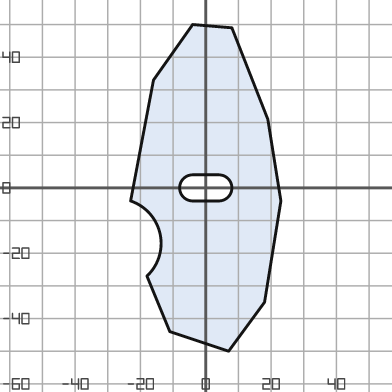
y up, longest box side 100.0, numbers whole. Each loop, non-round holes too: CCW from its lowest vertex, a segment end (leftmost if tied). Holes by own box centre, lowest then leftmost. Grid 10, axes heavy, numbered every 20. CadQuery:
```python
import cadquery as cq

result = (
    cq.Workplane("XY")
    .moveTo(7.0, -50.0)
    .lineTo(18.0, -35.0)
    .lineTo(23.0, -4.0)
    .lineTo(19.0, 21.0)
    .lineTo(8.0, 49.0)
    .lineTo(-4.0, 50.0)
    .lineTo(-16.0, 33.0)
    .lineTo(-23.0, -4.0)
    .threePointArc((-14.0, -14.0), (-18.0, -27.0))
    .lineTo(-11.0, -44.0)
    .close()
    .moveTo(-4.0, -4.0)
    .lineTo(4.0, -4.0)
    .threePointArc((8.0, 0.0), (4.0, 4.0))
    .lineTo(-4.0, 4.0)
    .threePointArc((-8.0, 0.0), (-4.0, -4.0))
    .close()
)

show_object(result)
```